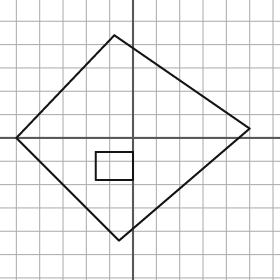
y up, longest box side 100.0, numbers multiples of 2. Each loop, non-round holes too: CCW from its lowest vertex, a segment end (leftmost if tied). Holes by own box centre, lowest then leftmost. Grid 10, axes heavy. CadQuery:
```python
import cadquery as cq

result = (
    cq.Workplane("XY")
    .moveTo(-6.0, -44.0)
    .lineTo(50.0, 4.0)
    .lineTo(-8.0, 44.0)
    .lineTo(-50.0, 0.0)
    .close()
    .moveTo(-16.0, -18.0)
    .lineTo(0.0, -18.0)
    .lineTo(0.0, -6.0)
    .lineTo(-16.0, -6.0)
    .close()
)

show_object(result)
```